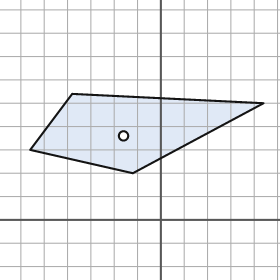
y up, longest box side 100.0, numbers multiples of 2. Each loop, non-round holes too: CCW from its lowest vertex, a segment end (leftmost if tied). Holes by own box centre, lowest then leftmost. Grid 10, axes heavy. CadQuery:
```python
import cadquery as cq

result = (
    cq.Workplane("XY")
    .moveTo(-12.0, 20.0)
    .lineTo(44.0, 50.0)
    .lineTo(-38.0, 54.0)
    .lineTo(-56.0, 30.0)
    .close()
    .moveTo(-16.0, 36.0)
    .circle(2.0)
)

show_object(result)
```